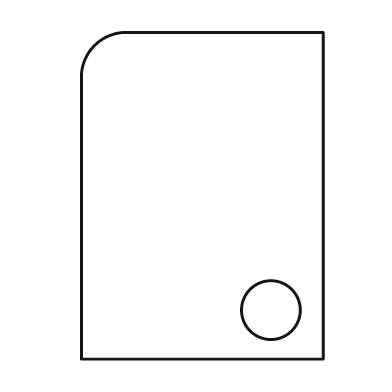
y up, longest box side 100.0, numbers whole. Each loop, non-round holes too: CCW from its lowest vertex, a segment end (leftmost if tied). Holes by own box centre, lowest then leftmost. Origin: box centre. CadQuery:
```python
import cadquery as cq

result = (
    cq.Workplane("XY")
    .moveTo(-37.0, -50.0)
    .lineTo(37.0, -50.0)
    .lineTo(37.0, 50.0)
    .lineTo(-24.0, 50.0)
    .threePointArc((-33.0, 46.0), (-37.0, 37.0))
    .close()
    .moveTo(21.0, -35.0)
    .circle(9.0)
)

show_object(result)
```